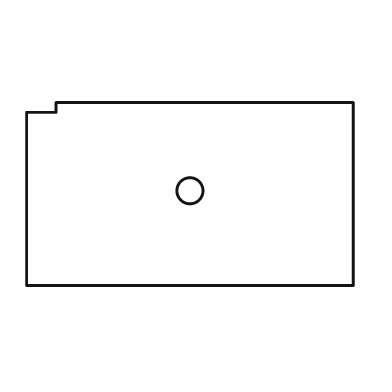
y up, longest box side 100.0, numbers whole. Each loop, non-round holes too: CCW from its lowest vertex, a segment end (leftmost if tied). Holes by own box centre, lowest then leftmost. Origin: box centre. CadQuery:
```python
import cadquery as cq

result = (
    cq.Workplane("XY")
    .moveTo(-50.0, -28.0)
    .lineTo(50.0, -28.0)
    .lineTo(50.0, 28.0)
    .lineTo(-41.0, 28.0)
    .lineTo(-41.0, 25.0)
    .lineTo(-50.0, 25.0)
    .close()
    .moveTo(0.0, 1.0)
    .circle(4.0)
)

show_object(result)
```